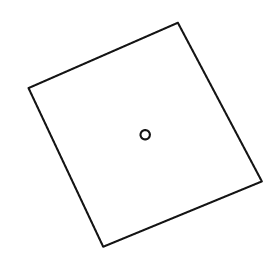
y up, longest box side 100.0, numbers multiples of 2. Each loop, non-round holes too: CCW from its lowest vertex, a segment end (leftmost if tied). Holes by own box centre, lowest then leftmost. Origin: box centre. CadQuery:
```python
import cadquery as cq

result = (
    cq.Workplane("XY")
    .moveTo(-18.0, -48.0)
    .lineTo(50.0, -20.0)
    .lineTo(14.0, 48.0)
    .lineTo(-50.0, 20.0)
    .close()
    .moveTo(0.0, 0.0)
    .circle(2.0)
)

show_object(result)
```